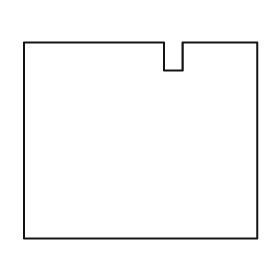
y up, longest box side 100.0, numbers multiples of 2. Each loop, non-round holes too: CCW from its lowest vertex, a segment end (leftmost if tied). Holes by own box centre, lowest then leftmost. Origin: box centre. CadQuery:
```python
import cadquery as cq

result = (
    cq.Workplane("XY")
    .moveTo(-50.0, -42.0)
    .lineTo(50.0, -42.0)
    .lineTo(50.0, 42.0)
    .lineTo(18.0, 42.0)
    .lineTo(18.0, 30.0)
    .lineTo(10.0, 30.0)
    .lineTo(10.0, 42.0)
    .lineTo(-50.0, 42.0)
    .close()
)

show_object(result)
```